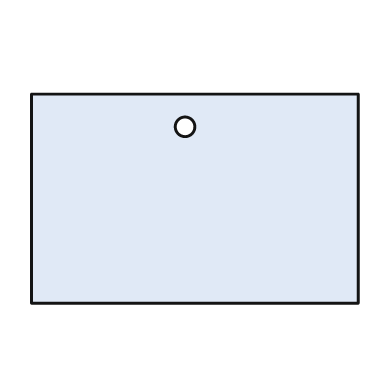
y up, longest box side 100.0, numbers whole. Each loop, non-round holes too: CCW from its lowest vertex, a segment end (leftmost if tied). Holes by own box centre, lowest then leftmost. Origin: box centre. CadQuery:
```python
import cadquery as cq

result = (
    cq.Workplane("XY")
    .moveTo(-50.0, -32.0)
    .lineTo(50.0, -32.0)
    .lineTo(50.0, 32.0)
    .lineTo(-50.0, 32.0)
    .close()
    .moveTo(-3.0, 22.0)
    .circle(3.0)
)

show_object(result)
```